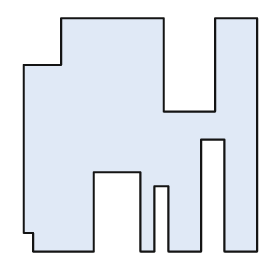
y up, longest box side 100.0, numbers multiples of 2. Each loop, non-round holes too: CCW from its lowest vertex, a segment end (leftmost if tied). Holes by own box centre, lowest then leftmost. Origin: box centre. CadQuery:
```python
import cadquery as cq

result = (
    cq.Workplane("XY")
    .moveTo(-46.0, -50.0)
    .lineTo(-20.0, -50.0)
    .lineTo(-20.0, -16.0)
    .lineTo(0.0, -16.0)
    .lineTo(0.0, -50.0)
    .lineTo(6.0, -50.0)
    .lineTo(6.0, -22.0)
    .lineTo(12.0, -22.0)
    .lineTo(12.0, -50.0)
    .lineTo(26.0, -50.0)
    .lineTo(26.0, -2.0)
    .lineTo(36.0, -2.0)
    .lineTo(36.0, -50.0)
    .lineTo(50.0, -50.0)
    .lineTo(50.0, 50.0)
    .lineTo(32.0, 50.0)
    .lineTo(32.0, 10.0)
    .lineTo(10.0, 10.0)
    .lineTo(10.0, 50.0)
    .lineTo(-34.0, 50.0)
    .lineTo(-34.0, 30.0)
    .lineTo(-50.0, 30.0)
    .lineTo(-50.0, -42.0)
    .lineTo(-46.0, -42.0)
    .close()
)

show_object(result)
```